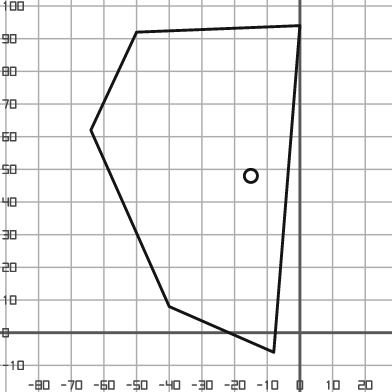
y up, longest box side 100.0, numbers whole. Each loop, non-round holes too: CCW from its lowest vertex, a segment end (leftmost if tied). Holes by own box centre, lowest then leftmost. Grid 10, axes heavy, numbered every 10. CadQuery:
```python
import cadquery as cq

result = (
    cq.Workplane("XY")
    .moveTo(-8.0, -6.0)
    .lineTo(0.0, 94.0)
    .lineTo(-50.0, 92.0)
    .lineTo(-64.0, 62.0)
    .lineTo(-40.0, 8.0)
    .close()
    .moveTo(-15.0, 48.0)
    .circle(2.0)
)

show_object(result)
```